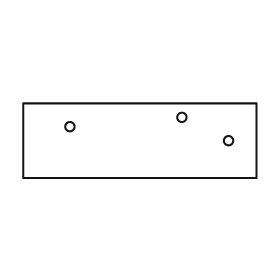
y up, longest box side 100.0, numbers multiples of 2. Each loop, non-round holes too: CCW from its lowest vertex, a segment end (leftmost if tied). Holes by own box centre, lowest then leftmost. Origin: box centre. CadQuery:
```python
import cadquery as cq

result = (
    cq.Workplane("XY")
    .moveTo(-50.0, -16.0)
    .lineTo(50.0, -16.0)
    .lineTo(50.0, 16.0)
    .lineTo(-50.0, 16.0)
    .close()
    .moveTo(38.0, 0.0)
    .circle(2.0)
    .moveTo(-30.0, 6.0)
    .circle(2.0)
    .moveTo(18.0, 10.0)
    .circle(2.0)
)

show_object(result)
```